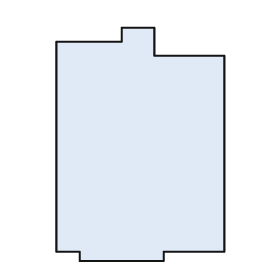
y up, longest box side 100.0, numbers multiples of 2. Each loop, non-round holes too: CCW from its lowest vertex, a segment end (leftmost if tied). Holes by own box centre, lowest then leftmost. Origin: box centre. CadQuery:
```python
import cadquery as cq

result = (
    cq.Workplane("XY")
    .moveTo(-26.0, -50.0)
    .lineTo(10.0, -50.0)
    .lineTo(10.0, -46.0)
    .lineTo(36.0, -46.0)
    .lineTo(36.0, 38.0)
    .lineTo(6.0, 38.0)
    .lineTo(6.0, 50.0)
    .lineTo(-8.0, 50.0)
    .lineTo(-8.0, 44.0)
    .lineTo(-36.0, 44.0)
    .lineTo(-36.0, -46.0)
    .lineTo(-26.0, -46.0)
    .close()
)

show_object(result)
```